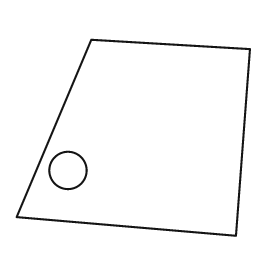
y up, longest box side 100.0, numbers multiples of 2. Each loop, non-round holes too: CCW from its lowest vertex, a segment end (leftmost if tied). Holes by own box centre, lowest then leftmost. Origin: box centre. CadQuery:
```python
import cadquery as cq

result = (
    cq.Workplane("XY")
    .moveTo(44.0, -42.0)
    .lineTo(50.0, 38.0)
    .lineTo(-18.0, 42.0)
    .lineTo(-50.0, -34.0)
    .close()
    .moveTo(-28.0, -14.0)
    .circle(8.0)
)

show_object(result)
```